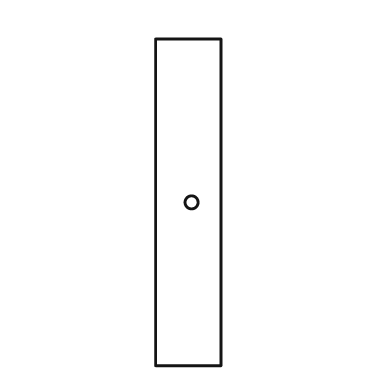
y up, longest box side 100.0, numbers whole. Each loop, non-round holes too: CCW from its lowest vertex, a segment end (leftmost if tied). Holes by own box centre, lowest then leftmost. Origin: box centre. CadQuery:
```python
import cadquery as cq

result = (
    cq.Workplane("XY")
    .moveTo(-10.0, -50.0)
    .lineTo(10.0, -50.0)
    .lineTo(10.0, 50.0)
    .lineTo(-10.0, 50.0)
    .close()
    .moveTo(1.0, 0.0)
    .circle(2.0)
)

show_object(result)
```